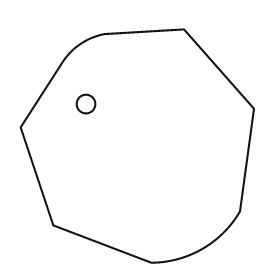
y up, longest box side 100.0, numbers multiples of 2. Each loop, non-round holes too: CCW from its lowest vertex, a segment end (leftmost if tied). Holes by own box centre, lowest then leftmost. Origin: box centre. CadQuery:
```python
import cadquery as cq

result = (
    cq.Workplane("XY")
    .moveTo(6.0, -50.0)
    .threePointArc((28.0, -44.0), (44.0, -28.0))
    .lineTo(50.0, 16.0)
    .lineTo(20.0, 50.0)
    .lineTo(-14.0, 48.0)
    .threePointArc((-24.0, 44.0), (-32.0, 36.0))
    .lineTo(-50.0, 8.0)
    .lineTo(-36.0, -34.0)
    .close()
    .moveTo(-22.0, 18.0)
    .circle(4.0)
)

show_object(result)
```